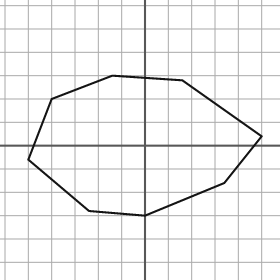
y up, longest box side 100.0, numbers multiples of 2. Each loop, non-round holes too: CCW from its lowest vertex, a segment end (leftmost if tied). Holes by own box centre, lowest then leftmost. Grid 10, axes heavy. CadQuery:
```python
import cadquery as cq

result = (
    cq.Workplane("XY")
    .moveTo(0.0, -30.0)
    .lineTo(34.0, -16.0)
    .lineTo(50.0, 4.0)
    .lineTo(16.0, 28.0)
    .lineTo(-14.0, 30.0)
    .lineTo(-40.0, 20.0)
    .lineTo(-50.0, -6.0)
    .lineTo(-24.0, -28.0)
    .close()
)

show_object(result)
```